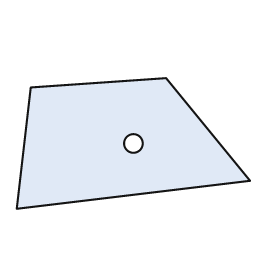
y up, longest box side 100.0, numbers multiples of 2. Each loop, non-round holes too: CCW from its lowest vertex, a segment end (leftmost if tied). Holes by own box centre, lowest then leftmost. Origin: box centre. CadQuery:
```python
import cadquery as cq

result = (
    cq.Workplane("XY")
    .moveTo(-50.0, -28.0)
    .lineTo(50.0, -16.0)
    .lineTo(14.0, 28.0)
    .lineTo(-44.0, 24.0)
    .close()
    .moveTo(0.0, 0.0)
    .circle(4.0)
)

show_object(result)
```